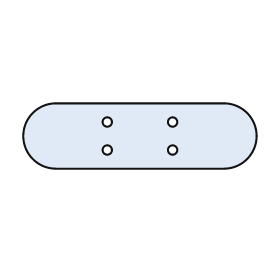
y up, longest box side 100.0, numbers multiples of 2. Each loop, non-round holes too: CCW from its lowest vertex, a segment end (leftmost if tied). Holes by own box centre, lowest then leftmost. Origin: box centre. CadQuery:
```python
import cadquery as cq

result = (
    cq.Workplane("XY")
    .moveTo(-36.0, -14.0)
    .lineTo(36.0, -14.0)
    .threePointArc((50.0, 0.0), (36.0, 14.0))
    .lineTo(-36.0, 14.0)
    .threePointArc((-50.0, 0.0), (-36.0, -14.0))
    .close()
    .moveTo(-14.0, -6.0)
    .circle(2.0)
    .moveTo(14.0, -6.0)
    .circle(2.0)
    .moveTo(-14.0, 6.0)
    .circle(2.0)
    .moveTo(14.0, 6.0)
    .circle(2.0)
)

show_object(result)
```